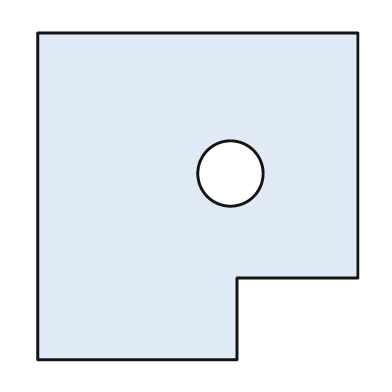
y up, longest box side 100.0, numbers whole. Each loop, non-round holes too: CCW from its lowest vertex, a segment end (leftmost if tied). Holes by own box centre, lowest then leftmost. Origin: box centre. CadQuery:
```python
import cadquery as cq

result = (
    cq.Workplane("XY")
    .moveTo(-49.0, -50.0)
    .lineTo(12.0, -50.0)
    .lineTo(12.0, -25.0)
    .lineTo(49.0, -25.0)
    .lineTo(49.0, 50.0)
    .lineTo(-49.0, 50.0)
    .close()
    .moveTo(10.0, 7.0)
    .circle(10.0)
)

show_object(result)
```